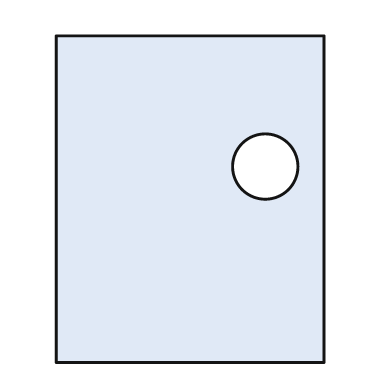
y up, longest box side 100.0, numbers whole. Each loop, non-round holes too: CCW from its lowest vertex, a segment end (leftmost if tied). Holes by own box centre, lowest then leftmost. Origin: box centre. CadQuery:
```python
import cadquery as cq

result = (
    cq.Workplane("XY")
    .moveTo(-41.0, -50.0)
    .lineTo(41.0, -50.0)
    .lineTo(41.0, 50.0)
    .lineTo(-41.0, 50.0)
    .close()
    .moveTo(23.0, 10.0)
    .circle(10.0)
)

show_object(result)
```